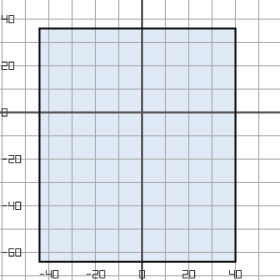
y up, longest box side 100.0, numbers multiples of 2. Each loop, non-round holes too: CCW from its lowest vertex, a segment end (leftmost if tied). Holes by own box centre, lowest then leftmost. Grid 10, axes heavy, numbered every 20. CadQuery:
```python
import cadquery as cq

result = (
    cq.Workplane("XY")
    .moveTo(-44.0, -64.0)
    .lineTo(40.0, -64.0)
    .lineTo(40.0, 36.0)
    .lineTo(-44.0, 36.0)
    .close()
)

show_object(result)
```